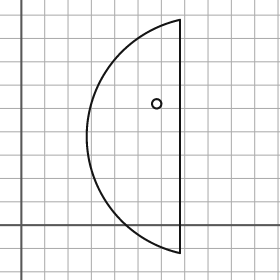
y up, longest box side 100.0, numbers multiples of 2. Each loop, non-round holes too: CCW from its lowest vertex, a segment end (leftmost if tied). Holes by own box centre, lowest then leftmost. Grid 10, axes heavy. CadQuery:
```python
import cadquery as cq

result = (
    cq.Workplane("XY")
    .moveTo(68.0, -12.0)
    .lineTo(68.0, 88.0)
    .threePointArc((28.0, 38.0), (68.0, -12.0))
    .close()
    .moveTo(58.0, 52.0)
    .circle(2.0)
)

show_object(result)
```